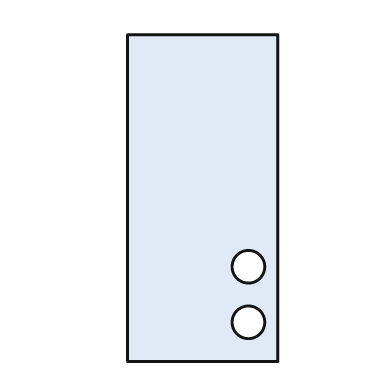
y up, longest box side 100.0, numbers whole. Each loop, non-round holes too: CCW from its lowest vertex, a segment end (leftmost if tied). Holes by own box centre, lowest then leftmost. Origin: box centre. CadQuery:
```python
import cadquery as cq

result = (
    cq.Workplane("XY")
    .moveTo(-23.0, -50.0)
    .lineTo(23.0, -50.0)
    .lineTo(23.0, 50.0)
    .lineTo(-23.0, 50.0)
    .close()
    .moveTo(14.0, -38.0)
    .circle(5.0)
    .moveTo(14.0, -21.0)
    .circle(5.0)
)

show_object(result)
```